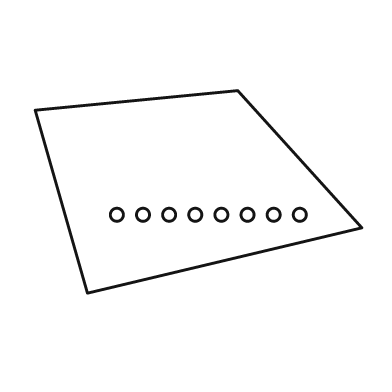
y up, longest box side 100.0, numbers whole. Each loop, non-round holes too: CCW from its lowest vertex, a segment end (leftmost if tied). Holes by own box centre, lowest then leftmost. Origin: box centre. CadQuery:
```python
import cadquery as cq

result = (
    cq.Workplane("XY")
    .moveTo(-34.0, -31.0)
    .lineTo(50.0, -11.0)
    .lineTo(12.0, 31.0)
    .lineTo(-50.0, 25.0)
    .close()
    .moveTo(-25.0, -7.0)
    .circle(2.0)
    .moveTo(-17.0, -7.0)
    .circle(2.0)
    .moveTo(-9.0, -7.0)
    .circle(2.0)
    .moveTo(-1.0, -7.0)
    .circle(2.0)
    .moveTo(7.0, -7.0)
    .circle(2.0)
    .moveTo(15.0, -7.0)
    .circle(2.0)
    .moveTo(23.0, -7.0)
    .circle(2.0)
    .moveTo(31.0, -7.0)
    .circle(2.0)
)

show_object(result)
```